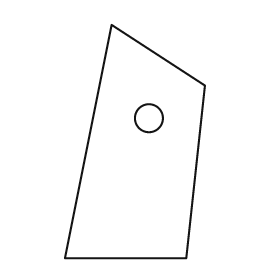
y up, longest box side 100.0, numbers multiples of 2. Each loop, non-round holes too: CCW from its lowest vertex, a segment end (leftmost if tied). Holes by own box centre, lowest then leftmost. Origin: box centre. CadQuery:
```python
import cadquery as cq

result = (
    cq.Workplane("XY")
    .moveTo(-30.0, -50.0)
    .lineTo(22.0, -50.0)
    .lineTo(30.0, 24.0)
    .lineTo(-10.0, 50.0)
    .close()
    .moveTo(6.0, 10.0)
    .circle(6.0)
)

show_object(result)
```